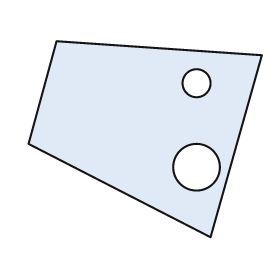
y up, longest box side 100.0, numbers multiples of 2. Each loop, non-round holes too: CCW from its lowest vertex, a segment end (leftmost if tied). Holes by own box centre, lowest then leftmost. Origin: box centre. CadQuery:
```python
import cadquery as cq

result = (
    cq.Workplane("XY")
    .moveTo(28.0, -42.0)
    .lineTo(50.0, 36.0)
    .lineTo(-38.0, 42.0)
    .lineTo(-50.0, -2.0)
    .close()
    .moveTo(22.0, -12.0)
    .circle(10.0)
    .moveTo(22.0, 24.0)
    .circle(6.0)
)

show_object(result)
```